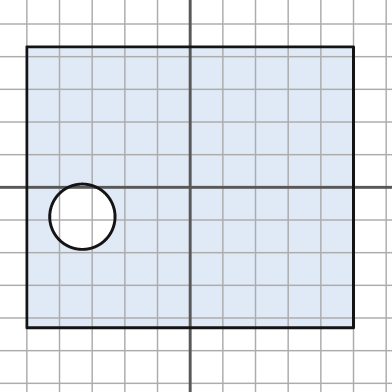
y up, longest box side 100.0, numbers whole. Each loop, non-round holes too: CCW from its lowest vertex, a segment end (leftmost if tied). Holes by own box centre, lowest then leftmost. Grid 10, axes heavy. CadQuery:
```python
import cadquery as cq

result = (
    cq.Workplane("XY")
    .moveTo(-50.0, -43.0)
    .lineTo(50.0, -43.0)
    .lineTo(50.0, 43.0)
    .lineTo(-50.0, 43.0)
    .close()
    .moveTo(-33.0, -9.0)
    .circle(10.0)
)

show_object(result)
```